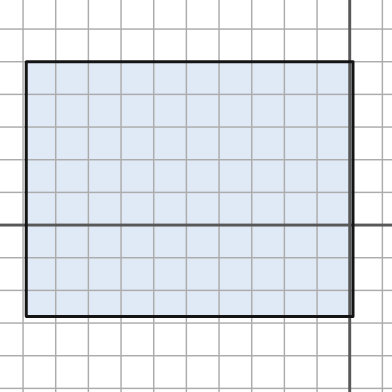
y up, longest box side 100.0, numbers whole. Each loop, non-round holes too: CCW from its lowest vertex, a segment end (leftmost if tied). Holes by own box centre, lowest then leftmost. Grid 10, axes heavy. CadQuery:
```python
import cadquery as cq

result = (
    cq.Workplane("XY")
    .moveTo(-99.0, -28.0)
    .lineTo(1.0, -28.0)
    .lineTo(1.0, 50.0)
    .lineTo(-99.0, 50.0)
    .close()
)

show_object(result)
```